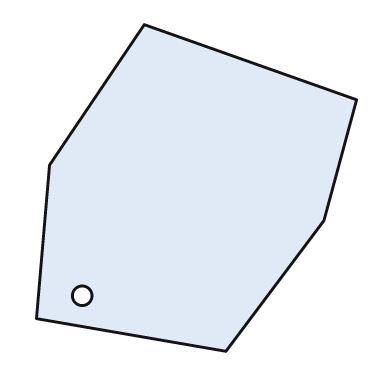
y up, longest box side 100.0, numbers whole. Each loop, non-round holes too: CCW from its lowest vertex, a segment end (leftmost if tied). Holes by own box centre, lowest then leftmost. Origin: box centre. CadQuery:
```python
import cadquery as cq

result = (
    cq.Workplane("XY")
    .moveTo(9.0, -50.0)
    .lineTo(39.0, -10.0)
    .lineTo(49.0, 27.0)
    .lineTo(-16.0, 50.0)
    .lineTo(-45.0, 7.0)
    .lineTo(-49.0, -40.0)
    .close()
    .moveTo(-35.0, -33.0)
    .circle(3.0)
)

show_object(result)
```